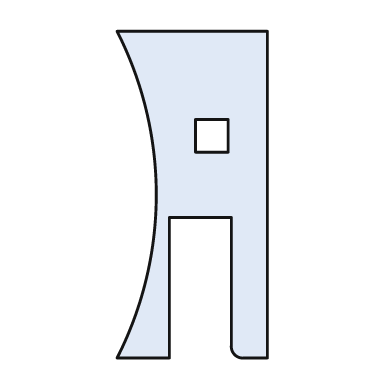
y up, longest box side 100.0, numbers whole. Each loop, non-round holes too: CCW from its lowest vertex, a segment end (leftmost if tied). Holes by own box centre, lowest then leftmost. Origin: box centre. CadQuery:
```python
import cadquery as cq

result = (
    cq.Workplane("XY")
    .moveTo(-23.0, -50.0)
    .lineTo(-7.0, -50.0)
    .lineTo(-7.0, -7.0)
    .lineTo(12.0, -7.0)
    .lineTo(12.0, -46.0)
    .threePointArc((13.0, -49.0), (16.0, -50.0))
    .lineTo(23.0, -50.0)
    .lineTo(23.0, 50.0)
    .lineTo(-23.0, 50.0)
    .threePointArc((-11.0, 0.0), (-23.0, -50.0))
    .close()
    .moveTo(1.0, 13.0)
    .lineTo(11.0, 13.0)
    .lineTo(11.0, 23.0)
    .lineTo(1.0, 23.0)
    .close()
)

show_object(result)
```